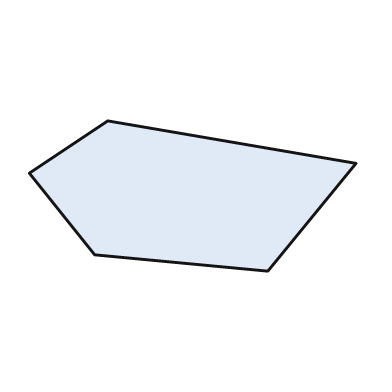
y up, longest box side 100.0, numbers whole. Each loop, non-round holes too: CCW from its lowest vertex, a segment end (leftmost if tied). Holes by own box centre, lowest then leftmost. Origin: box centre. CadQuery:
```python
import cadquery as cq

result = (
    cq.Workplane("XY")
    .moveTo(23.0, -23.0)
    .lineTo(50.0, 10.0)
    .lineTo(-26.0, 23.0)
    .lineTo(-50.0, 7.0)
    .lineTo(-30.0, -18.0)
    .close()
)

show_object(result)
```